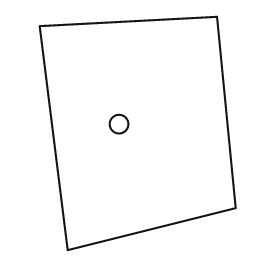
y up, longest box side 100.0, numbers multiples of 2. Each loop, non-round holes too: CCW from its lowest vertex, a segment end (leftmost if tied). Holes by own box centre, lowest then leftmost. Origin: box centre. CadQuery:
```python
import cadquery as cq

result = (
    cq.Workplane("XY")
    .moveTo(-30.0, -50.0)
    .lineTo(42.0, -32.0)
    .lineTo(34.0, 50.0)
    .lineTo(-42.0, 46.0)
    .close()
    .moveTo(-8.0, 4.0)
    .circle(4.0)
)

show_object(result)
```